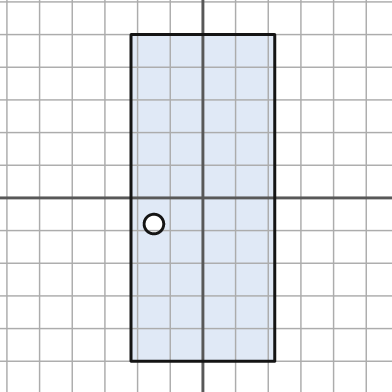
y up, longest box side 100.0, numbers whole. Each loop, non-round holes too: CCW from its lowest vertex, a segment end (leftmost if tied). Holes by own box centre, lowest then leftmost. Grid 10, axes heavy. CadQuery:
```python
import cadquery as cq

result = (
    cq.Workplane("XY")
    .moveTo(-22.0, -50.0)
    .lineTo(22.0, -50.0)
    .lineTo(22.0, 50.0)
    .lineTo(-22.0, 50.0)
    .close()
    .moveTo(-15.0, -8.0)
    .circle(3.0)
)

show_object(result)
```